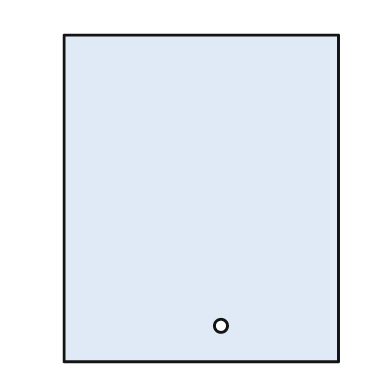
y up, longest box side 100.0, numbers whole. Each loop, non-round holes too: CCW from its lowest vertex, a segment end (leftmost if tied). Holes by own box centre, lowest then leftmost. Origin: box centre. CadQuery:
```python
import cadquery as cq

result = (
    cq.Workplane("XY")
    .moveTo(-42.0, -50.0)
    .lineTo(42.0, -50.0)
    .lineTo(42.0, 50.0)
    .lineTo(-42.0, 50.0)
    .close()
    .moveTo(6.0, -39.0)
    .circle(2.0)
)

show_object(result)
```